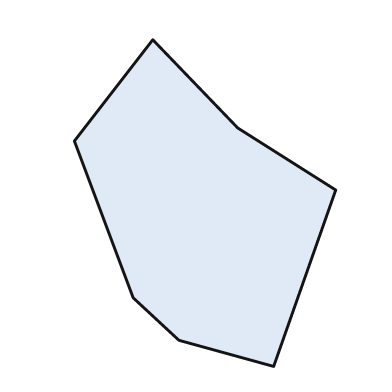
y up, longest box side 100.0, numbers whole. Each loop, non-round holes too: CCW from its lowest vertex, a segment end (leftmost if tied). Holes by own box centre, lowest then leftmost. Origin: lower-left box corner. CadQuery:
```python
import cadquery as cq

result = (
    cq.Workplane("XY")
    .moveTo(61.0, 0.0)
    .lineTo(80.0, 54.0)
    .lineTo(50.0, 73.0)
    .lineTo(24.0, 100.0)
    .lineTo(0.0, 69.0)
    .lineTo(18.0, 21.0)
    .lineTo(32.0, 8.0)
    .close()
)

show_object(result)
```